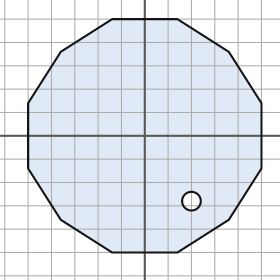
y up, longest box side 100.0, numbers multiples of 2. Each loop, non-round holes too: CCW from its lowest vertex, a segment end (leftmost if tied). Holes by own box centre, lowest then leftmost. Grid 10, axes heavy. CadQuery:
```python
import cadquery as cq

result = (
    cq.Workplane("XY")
    .moveTo(-14.0, -50.0)
    .lineTo(14.0, -50.0)
    .lineTo(36.0, -36.0)
    .lineTo(50.0, -14.0)
    .lineTo(50.0, 14.0)
    .lineTo(36.0, 36.0)
    .lineTo(14.0, 50.0)
    .lineTo(-14.0, 50.0)
    .lineTo(-36.0, 36.0)
    .lineTo(-50.0, 14.0)
    .lineTo(-50.0, -14.0)
    .lineTo(-36.0, -36.0)
    .close()
    .moveTo(20.0, -28.0)
    .circle(4.0)
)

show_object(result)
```